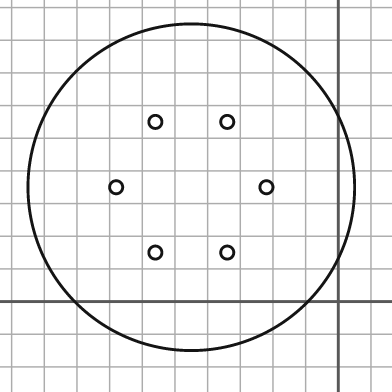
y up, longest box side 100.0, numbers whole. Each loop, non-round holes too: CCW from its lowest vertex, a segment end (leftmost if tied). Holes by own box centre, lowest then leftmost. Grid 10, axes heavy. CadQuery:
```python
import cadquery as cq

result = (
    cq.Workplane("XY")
    .moveTo(-45.0, 35.0)
    .circle(50.0)
    .moveTo(-56.0, 15.0)
    .circle(2.0)
    .moveTo(-34.0, 15.0)
    .circle(2.0)
    .moveTo(-68.0, 35.0)
    .circle(2.0)
    .moveTo(-22.0, 35.0)
    .circle(2.0)
    .moveTo(-56.0, 55.0)
    .circle(2.0)
    .moveTo(-34.0, 55.0)
    .circle(2.0)
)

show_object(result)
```